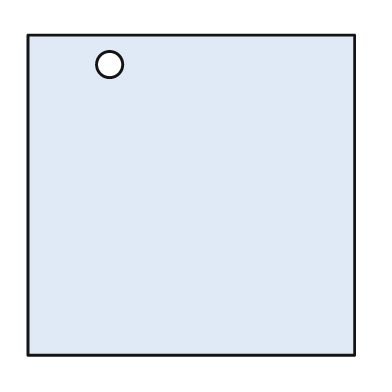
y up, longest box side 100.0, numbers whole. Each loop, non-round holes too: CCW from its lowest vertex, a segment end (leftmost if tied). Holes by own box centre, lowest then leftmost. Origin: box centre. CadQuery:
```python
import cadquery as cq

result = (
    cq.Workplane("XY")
    .moveTo(-50.0, -49.0)
    .lineTo(50.0, -49.0)
    .lineTo(50.0, 49.0)
    .lineTo(-50.0, 49.0)
    .close()
    .moveTo(-25.0, 40.0)
    .circle(4.0)
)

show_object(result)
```